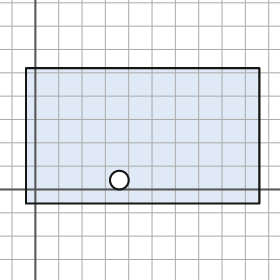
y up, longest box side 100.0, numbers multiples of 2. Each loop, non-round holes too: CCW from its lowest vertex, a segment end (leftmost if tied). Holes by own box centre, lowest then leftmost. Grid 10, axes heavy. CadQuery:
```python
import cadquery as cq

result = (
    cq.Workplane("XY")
    .moveTo(-4.0, -6.0)
    .lineTo(96.0, -6.0)
    .lineTo(96.0, 52.0)
    .lineTo(-4.0, 52.0)
    .close()
    .moveTo(36.0, 4.0)
    .circle(4.0)
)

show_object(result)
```